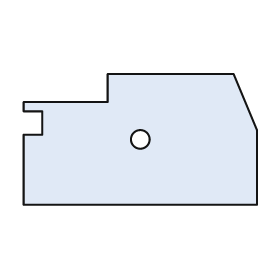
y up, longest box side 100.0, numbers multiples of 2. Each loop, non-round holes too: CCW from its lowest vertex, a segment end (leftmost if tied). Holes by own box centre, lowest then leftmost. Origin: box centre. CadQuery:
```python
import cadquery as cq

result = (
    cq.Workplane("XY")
    .moveTo(-50.0, -28.0)
    .lineTo(50.0, -28.0)
    .lineTo(50.0, 4.0)
    .lineTo(40.0, 28.0)
    .lineTo(-14.0, 28.0)
    .lineTo(-14.0, 16.0)
    .lineTo(-50.0, 16.0)
    .lineTo(-50.0, 12.0)
    .lineTo(-42.0, 12.0)
    .lineTo(-42.0, 2.0)
    .lineTo(-50.0, 2.0)
    .close()
    .moveTo(0.0, 0.0)
    .circle(4.0)
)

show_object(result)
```